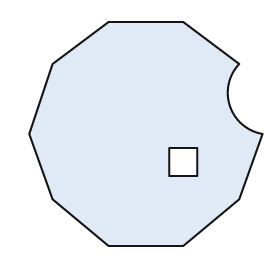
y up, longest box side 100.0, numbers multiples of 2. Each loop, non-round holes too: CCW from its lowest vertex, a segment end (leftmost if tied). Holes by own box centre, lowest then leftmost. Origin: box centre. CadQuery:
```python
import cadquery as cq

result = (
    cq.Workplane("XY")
    .moveTo(-16.0, -48.0)
    .lineTo(16.0, -48.0)
    .lineTo(40.0, -28.0)
    .lineTo(50.0, 0.0)
    .threePointArc((36.0, 12.0), (40.0, 30.0))
    .lineTo(16.0, 48.0)
    .lineTo(-16.0, 48.0)
    .lineTo(-40.0, 30.0)
    .lineTo(-50.0, 0.0)
    .lineTo(-40.0, -28.0)
    .close()
    .moveTo(10.0, -18.0)
    .lineTo(22.0, -18.0)
    .lineTo(22.0, -6.0)
    .lineTo(10.0, -6.0)
    .close()
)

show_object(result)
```